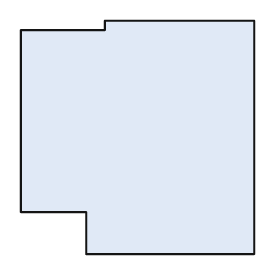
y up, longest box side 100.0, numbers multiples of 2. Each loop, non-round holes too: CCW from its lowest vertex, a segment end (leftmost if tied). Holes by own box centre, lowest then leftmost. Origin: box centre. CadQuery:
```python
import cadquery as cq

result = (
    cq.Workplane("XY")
    .moveTo(-22.0, -50.0)
    .lineTo(50.0, -50.0)
    .lineTo(50.0, 50.0)
    .lineTo(-14.0, 50.0)
    .lineTo(-14.0, 46.0)
    .lineTo(-50.0, 46.0)
    .lineTo(-50.0, -32.0)
    .lineTo(-22.0, -32.0)
    .close()
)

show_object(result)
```